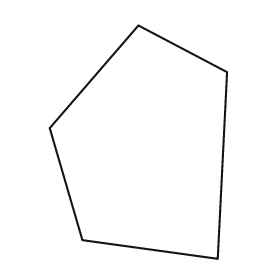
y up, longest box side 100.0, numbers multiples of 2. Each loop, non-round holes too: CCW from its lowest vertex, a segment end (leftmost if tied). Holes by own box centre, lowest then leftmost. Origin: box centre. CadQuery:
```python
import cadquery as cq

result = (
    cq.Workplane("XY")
    .moveTo(34.0, -50.0)
    .lineTo(38.0, 30.0)
    .lineTo(0.0, 50.0)
    .lineTo(-38.0, 6.0)
    .lineTo(-24.0, -42.0)
    .close()
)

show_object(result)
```